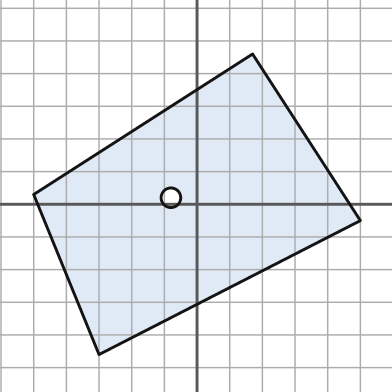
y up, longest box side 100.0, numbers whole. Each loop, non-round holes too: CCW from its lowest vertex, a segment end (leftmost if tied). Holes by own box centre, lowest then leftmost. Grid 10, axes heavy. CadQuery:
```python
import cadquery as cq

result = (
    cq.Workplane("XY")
    .moveTo(-30.0, -46.0)
    .lineTo(50.0, -5.0)
    .lineTo(17.0, 46.0)
    .lineTo(-50.0, 3.0)
    .close()
    .moveTo(-8.0, 2.0)
    .circle(3.0)
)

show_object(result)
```